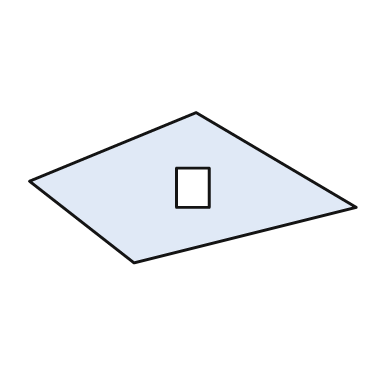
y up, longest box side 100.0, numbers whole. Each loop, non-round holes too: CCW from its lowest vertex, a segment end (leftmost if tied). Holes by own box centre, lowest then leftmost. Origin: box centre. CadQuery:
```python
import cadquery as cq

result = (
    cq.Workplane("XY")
    .moveTo(-18.0, -23.0)
    .lineTo(50.0, -6.0)
    .lineTo(1.0, 23.0)
    .lineTo(-50.0, 2.0)
    .close()
    .moveTo(-5.0, -6.0)
    .lineTo(5.0, -6.0)
    .lineTo(5.0, 6.0)
    .lineTo(-5.0, 6.0)
    .close()
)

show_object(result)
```